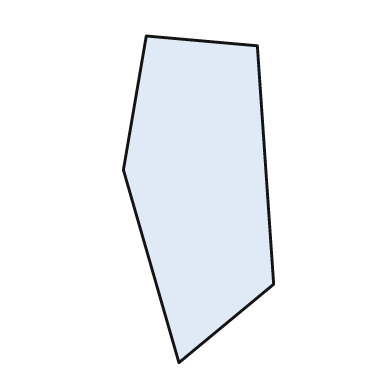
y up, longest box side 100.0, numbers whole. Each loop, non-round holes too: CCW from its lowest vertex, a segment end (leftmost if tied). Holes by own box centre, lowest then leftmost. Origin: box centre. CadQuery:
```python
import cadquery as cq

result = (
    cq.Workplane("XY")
    .moveTo(-6.0, -50.0)
    .lineTo(23.0, -26.0)
    .lineTo(18.0, 47.0)
    .lineTo(-16.0, 50.0)
    .lineTo(-23.0, 9.0)
    .close()
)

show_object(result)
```